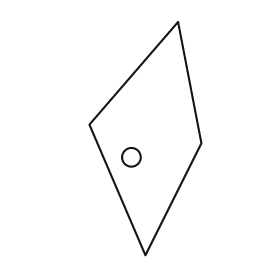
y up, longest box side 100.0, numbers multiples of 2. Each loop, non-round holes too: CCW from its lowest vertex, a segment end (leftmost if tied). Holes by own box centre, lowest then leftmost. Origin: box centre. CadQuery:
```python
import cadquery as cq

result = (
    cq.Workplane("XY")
    .moveTo(0.0, -50.0)
    .lineTo(24.0, -2.0)
    .lineTo(14.0, 50.0)
    .lineTo(-24.0, 6.0)
    .close()
    .moveTo(-6.0, -8.0)
    .circle(4.0)
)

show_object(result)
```